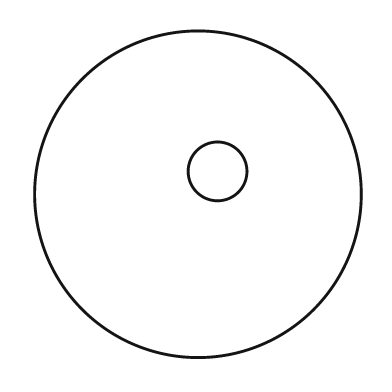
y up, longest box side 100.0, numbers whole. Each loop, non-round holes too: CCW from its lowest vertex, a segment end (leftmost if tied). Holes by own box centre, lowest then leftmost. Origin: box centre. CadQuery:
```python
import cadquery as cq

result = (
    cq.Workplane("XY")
    .moveTo(0.0, 0.0)
    .circle(50.0)
    .moveTo(6.0, 7.0)
    .circle(9.0)
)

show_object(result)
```